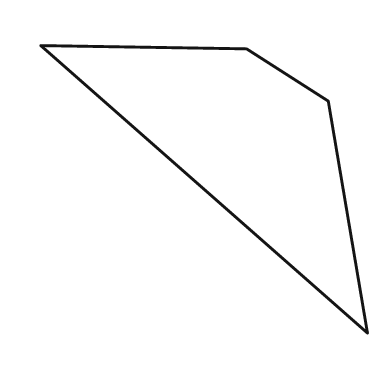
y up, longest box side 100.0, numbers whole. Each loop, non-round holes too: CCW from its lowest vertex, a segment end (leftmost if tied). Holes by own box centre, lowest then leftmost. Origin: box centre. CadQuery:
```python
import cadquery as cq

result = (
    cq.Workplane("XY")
    .moveTo(50.0, -44.0)
    .lineTo(38.0, 27.0)
    .lineTo(13.0, 43.0)
    .lineTo(-50.0, 44.0)
    .close()
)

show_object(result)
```